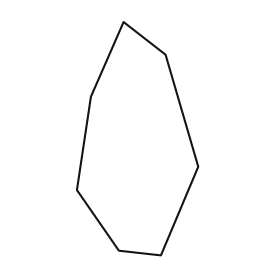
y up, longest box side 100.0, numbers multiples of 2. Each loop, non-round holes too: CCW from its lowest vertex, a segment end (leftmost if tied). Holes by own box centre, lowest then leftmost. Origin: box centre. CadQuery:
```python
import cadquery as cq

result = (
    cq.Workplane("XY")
    .moveTo(10.0, -50.0)
    .lineTo(26.0, -12.0)
    .lineTo(12.0, 36.0)
    .lineTo(-6.0, 50.0)
    .lineTo(-20.0, 18.0)
    .lineTo(-26.0, -22.0)
    .lineTo(-8.0, -48.0)
    .close()
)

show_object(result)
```